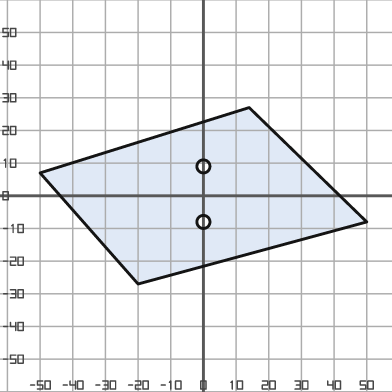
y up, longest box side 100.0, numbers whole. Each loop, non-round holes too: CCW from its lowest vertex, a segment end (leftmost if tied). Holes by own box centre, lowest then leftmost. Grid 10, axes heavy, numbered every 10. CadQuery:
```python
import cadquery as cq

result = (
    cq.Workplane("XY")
    .moveTo(-20.0, -27.0)
    .lineTo(50.0, -8.0)
    .lineTo(14.0, 27.0)
    .lineTo(-50.0, 7.0)
    .close()
    .moveTo(0.0, -8.0)
    .circle(2.0)
    .moveTo(0.0, 9.0)
    .circle(2.0)
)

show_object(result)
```